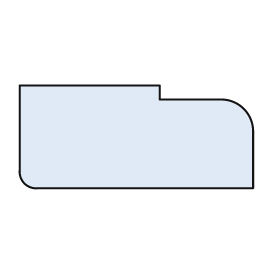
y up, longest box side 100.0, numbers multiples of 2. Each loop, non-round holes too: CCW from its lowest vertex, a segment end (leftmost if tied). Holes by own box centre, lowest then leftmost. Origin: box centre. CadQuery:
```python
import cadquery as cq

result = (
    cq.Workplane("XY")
    .moveTo(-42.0, -22.0)
    .lineTo(50.0, -22.0)
    .lineTo(50.0, 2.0)
    .threePointArc((46.0, 12.0), (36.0, 16.0))
    .lineTo(10.0, 16.0)
    .lineTo(10.0, 22.0)
    .lineTo(-50.0, 22.0)
    .lineTo(-50.0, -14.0)
    .threePointArc((-48.0, -20.0), (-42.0, -22.0))
    .close()
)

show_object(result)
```